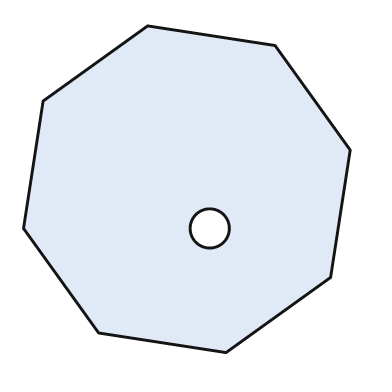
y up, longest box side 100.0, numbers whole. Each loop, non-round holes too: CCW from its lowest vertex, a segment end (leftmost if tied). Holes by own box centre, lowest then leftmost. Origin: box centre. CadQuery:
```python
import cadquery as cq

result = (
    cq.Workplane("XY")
    .moveTo(12.0, -50.0)
    .lineTo(44.0, -27.0)
    .lineTo(50.0, 12.0)
    .lineTo(27.0, 44.0)
    .lineTo(-12.0, 50.0)
    .lineTo(-44.0, 27.0)
    .lineTo(-50.0, -12.0)
    .lineTo(-27.0, -44.0)
    .close()
    .moveTo(7.0, -12.0)
    .circle(6.0)
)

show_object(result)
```